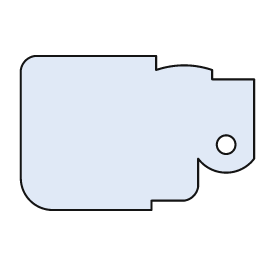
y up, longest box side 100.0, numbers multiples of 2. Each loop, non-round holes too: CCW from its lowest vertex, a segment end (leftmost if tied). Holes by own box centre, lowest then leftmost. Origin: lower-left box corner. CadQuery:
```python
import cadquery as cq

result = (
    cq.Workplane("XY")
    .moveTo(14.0, 0.0)
    .lineTo(56.0, 0.0)
    .lineTo(56.0, 4.0)
    .lineTo(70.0, 4.0)
    .threePointArc((74.0, 6.0), (76.0, 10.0))
    .lineTo(76.0, 22.0)
    .threePointArc((88.0, 16.0), (100.0, 22.0))
    .lineTo(100.0, 56.0)
    .lineTo(82.0, 56.0)
    .lineTo(82.0, 60.0)
    .threePointArc((70.0, 62.0), (58.0, 60.0))
    .lineTo(58.0, 66.0)
    .lineTo(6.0, 66.0)
    .threePointArc((2.0, 64.0), (0.0, 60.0))
    .lineTo(0.0, 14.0)
    .threePointArc((4.0, 4.0), (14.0, 0.0))
    .close()
    .moveTo(88.0, 28.0)
    .circle(4.0)
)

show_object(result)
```